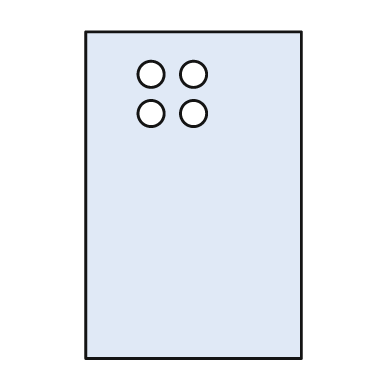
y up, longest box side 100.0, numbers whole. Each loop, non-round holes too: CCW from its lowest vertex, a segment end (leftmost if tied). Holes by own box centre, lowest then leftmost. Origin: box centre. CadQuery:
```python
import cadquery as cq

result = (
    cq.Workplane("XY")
    .moveTo(-33.0, -50.0)
    .lineTo(33.0, -50.0)
    .lineTo(33.0, 50.0)
    .lineTo(-33.0, 50.0)
    .close()
    .moveTo(-13.0, 25.0)
    .circle(4.0)
    .moveTo(0.0, 25.0)
    .circle(4.0)
    .moveTo(-13.0, 37.0)
    .circle(4.0)
    .moveTo(0.0, 37.0)
    .circle(4.0)
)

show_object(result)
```